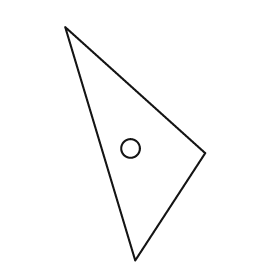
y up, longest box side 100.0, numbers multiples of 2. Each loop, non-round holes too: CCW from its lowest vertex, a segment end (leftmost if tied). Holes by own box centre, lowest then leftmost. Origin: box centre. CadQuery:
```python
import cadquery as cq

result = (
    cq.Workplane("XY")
    .moveTo(0.0, -50.0)
    .lineTo(30.0, -4.0)
    .lineTo(-30.0, 50.0)
    .close()
    .moveTo(-2.0, -2.0)
    .circle(4.0)
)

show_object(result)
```